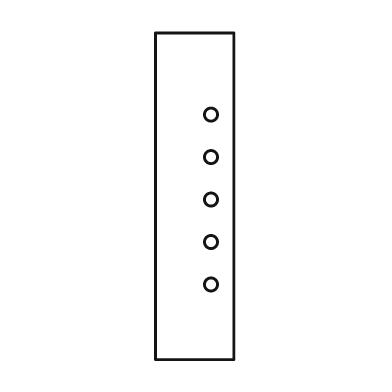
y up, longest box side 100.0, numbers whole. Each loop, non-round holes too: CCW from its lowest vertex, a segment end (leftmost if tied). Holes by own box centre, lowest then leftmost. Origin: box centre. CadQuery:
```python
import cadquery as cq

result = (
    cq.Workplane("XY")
    .moveTo(-12.0, -50.0)
    .lineTo(12.0, -50.0)
    .lineTo(12.0, 50.0)
    .lineTo(-12.0, 50.0)
    .close()
    .moveTo(5.0, -27.0)
    .circle(2.0)
    .moveTo(5.0, -14.0)
    .circle(2.0)
    .moveTo(5.0, -1.0)
    .circle(2.0)
    .moveTo(5.0, 12.0)
    .circle(2.0)
    .moveTo(5.0, 25.0)
    .circle(2.0)
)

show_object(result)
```